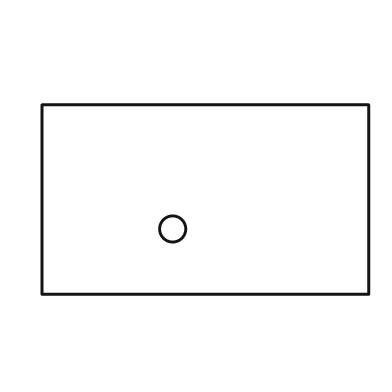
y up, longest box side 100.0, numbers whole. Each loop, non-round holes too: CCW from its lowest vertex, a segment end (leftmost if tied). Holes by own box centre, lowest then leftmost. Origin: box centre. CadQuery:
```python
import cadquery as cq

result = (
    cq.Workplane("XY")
    .moveTo(-50.0, -29.0)
    .lineTo(50.0, -29.0)
    .lineTo(50.0, 29.0)
    .lineTo(-50.0, 29.0)
    .close()
    .moveTo(-10.0, -9.0)
    .circle(4.0)
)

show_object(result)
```